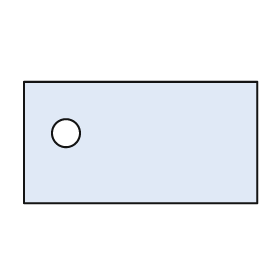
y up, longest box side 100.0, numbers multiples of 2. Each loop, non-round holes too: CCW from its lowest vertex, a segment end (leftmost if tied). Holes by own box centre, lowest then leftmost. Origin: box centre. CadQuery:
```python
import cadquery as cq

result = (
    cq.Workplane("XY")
    .moveTo(-50.0, -26.0)
    .lineTo(50.0, -26.0)
    .lineTo(50.0, 26.0)
    .lineTo(-50.0, 26.0)
    .close()
    .moveTo(-32.0, 4.0)
    .circle(6.0)
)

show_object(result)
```